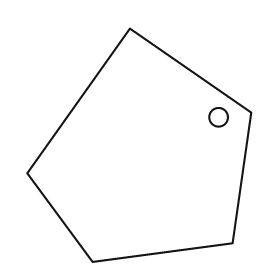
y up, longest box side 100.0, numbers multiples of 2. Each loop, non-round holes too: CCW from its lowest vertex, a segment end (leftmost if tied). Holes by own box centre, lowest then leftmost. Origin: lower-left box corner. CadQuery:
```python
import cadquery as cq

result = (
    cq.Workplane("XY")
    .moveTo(28.0, 0.0)
    .lineTo(88.0, 8.0)
    .lineTo(96.0, 64.0)
    .lineTo(44.0, 100.0)
    .lineTo(0.0, 38.0)
    .close()
    .moveTo(82.0, 62.0)
    .circle(4.0)
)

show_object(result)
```